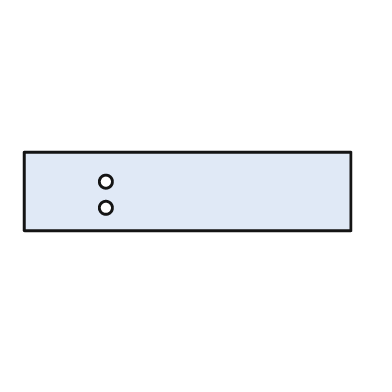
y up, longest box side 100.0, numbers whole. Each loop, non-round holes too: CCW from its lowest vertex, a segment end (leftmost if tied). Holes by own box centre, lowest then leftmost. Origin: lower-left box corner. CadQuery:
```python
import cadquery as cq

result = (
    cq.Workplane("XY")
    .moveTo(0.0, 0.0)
    .lineTo(100.0, 0.0)
    .lineTo(100.0, 24.0)
    .lineTo(0.0, 24.0)
    .close()
    .moveTo(25.0, 7.0)
    .circle(2.0)
    .moveTo(25.0, 15.0)
    .circle(2.0)
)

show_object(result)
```